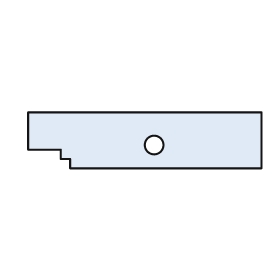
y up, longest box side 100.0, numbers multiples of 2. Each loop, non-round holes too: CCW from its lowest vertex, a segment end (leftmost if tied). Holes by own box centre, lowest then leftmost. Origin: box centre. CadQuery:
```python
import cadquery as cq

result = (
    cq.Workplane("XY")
    .moveTo(-32.0, -12.0)
    .lineTo(50.0, -12.0)
    .lineTo(50.0, 12.0)
    .lineTo(-50.0, 12.0)
    .lineTo(-50.0, -4.0)
    .lineTo(-36.0, -4.0)
    .lineTo(-36.0, -8.0)
    .lineTo(-32.0, -8.0)
    .close()
    .moveTo(4.0, -2.0)
    .circle(4.0)
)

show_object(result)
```